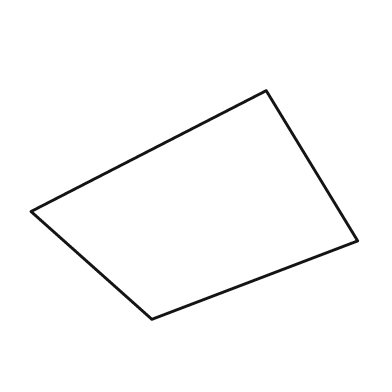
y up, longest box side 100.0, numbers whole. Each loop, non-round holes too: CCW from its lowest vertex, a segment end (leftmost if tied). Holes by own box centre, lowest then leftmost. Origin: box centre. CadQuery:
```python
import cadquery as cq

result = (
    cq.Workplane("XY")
    .moveTo(-13.0, -35.0)
    .lineTo(50.0, -11.0)
    .lineTo(22.0, 35.0)
    .lineTo(-50.0, -2.0)
    .close()
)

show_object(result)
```